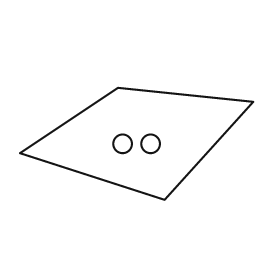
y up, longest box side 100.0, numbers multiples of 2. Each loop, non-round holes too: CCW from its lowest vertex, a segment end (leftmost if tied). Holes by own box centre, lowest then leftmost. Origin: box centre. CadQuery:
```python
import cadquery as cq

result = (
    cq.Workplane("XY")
    .moveTo(12.0, -24.0)
    .lineTo(50.0, 18.0)
    .lineTo(-8.0, 24.0)
    .lineTo(-50.0, -4.0)
    .close()
    .moveTo(-6.0, 0.0)
    .circle(4.0)
    .moveTo(6.0, 0.0)
    .circle(4.0)
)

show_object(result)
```